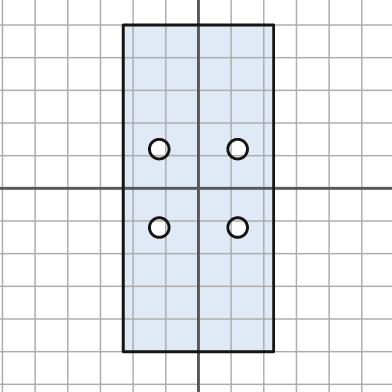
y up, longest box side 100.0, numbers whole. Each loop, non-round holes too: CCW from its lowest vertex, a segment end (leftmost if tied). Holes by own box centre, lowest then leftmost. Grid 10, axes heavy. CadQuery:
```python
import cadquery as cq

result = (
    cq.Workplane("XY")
    .moveTo(-23.0, -50.0)
    .lineTo(23.0, -50.0)
    .lineTo(23.0, 50.0)
    .lineTo(-23.0, 50.0)
    .close()
    .moveTo(-12.0, -12.0)
    .circle(3.0)
    .moveTo(12.0, -12.0)
    .circle(3.0)
    .moveTo(-12.0, 12.0)
    .circle(3.0)
    .moveTo(12.0, 12.0)
    .circle(3.0)
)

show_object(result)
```